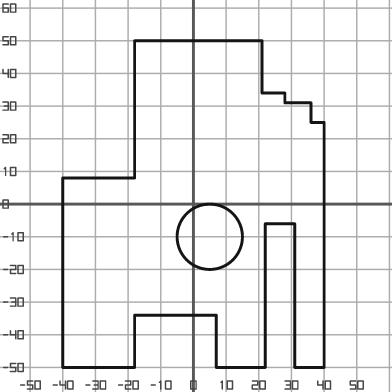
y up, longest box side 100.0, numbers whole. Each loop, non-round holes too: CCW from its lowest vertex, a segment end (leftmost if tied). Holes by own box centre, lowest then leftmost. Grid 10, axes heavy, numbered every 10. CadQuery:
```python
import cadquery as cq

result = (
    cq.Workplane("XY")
    .moveTo(-40.0, -50.0)
    .lineTo(-18.0, -50.0)
    .lineTo(-18.0, -34.0)
    .lineTo(7.0, -34.0)
    .lineTo(7.0, -50.0)
    .lineTo(22.0, -50.0)
    .lineTo(22.0, -6.0)
    .lineTo(31.0, -6.0)
    .lineTo(31.0, -50.0)
    .lineTo(40.0, -50.0)
    .lineTo(40.0, 25.0)
    .lineTo(36.0, 25.0)
    .lineTo(36.0, 31.0)
    .lineTo(28.0, 31.0)
    .lineTo(28.0, 34.0)
    .lineTo(21.0, 34.0)
    .lineTo(21.0, 50.0)
    .lineTo(-18.0, 50.0)
    .lineTo(-18.0, 8.0)
    .lineTo(-40.0, 8.0)
    .close()
    .moveTo(5.0, -10.0)
    .circle(10.0)
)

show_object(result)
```